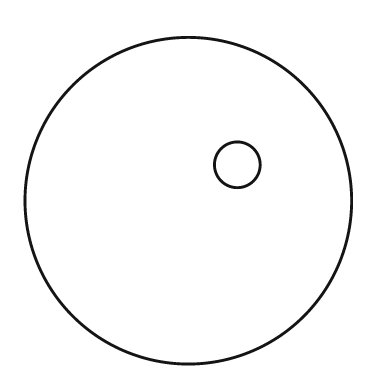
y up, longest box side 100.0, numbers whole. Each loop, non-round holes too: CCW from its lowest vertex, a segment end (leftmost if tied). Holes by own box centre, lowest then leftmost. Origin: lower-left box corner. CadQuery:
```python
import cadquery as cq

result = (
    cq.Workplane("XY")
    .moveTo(50.0, 50.0)
    .circle(50.0)
    .moveTo(65.0, 61.0)
    .circle(7.0)
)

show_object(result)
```